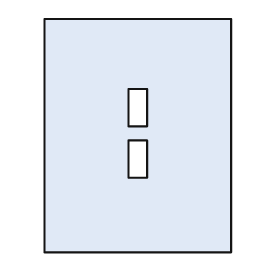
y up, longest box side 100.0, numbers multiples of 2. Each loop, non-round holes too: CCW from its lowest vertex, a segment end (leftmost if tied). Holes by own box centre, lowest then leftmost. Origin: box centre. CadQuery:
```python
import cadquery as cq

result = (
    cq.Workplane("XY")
    .moveTo(-40.0, -50.0)
    .lineTo(40.0, -50.0)
    .lineTo(40.0, 50.0)
    .lineTo(-40.0, 50.0)
    .close()
    .moveTo(-4.0, -18.0)
    .lineTo(4.0, -18.0)
    .lineTo(4.0, -2.0)
    .lineTo(-4.0, -2.0)
    .close()
    .moveTo(-4.0, 4.0)
    .lineTo(4.0, 4.0)
    .lineTo(4.0, 20.0)
    .lineTo(-4.0, 20.0)
    .close()
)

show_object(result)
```